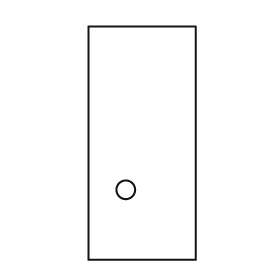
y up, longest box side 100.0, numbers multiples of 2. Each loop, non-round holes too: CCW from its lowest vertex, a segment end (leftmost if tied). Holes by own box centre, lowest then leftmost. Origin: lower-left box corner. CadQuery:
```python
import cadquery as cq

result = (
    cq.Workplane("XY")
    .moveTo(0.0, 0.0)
    .lineTo(46.0, 0.0)
    .lineTo(46.0, 100.0)
    .lineTo(0.0, 100.0)
    .close()
    .moveTo(16.0, 30.0)
    .circle(4.0)
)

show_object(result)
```